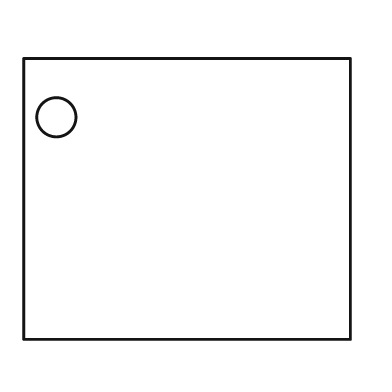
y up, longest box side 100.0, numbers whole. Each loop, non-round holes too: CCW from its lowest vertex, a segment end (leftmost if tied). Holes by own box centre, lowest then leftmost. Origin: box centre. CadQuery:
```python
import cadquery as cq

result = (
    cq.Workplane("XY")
    .moveTo(-50.0, -43.0)
    .lineTo(50.0, -43.0)
    .lineTo(50.0, 43.0)
    .lineTo(-50.0, 43.0)
    .close()
    .moveTo(-40.0, 25.0)
    .circle(6.0)
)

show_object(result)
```